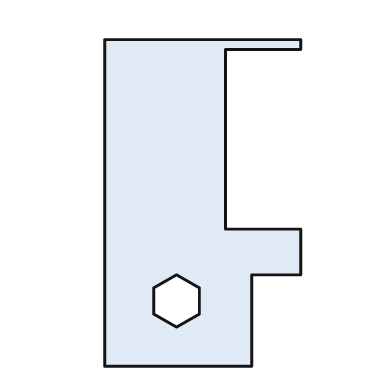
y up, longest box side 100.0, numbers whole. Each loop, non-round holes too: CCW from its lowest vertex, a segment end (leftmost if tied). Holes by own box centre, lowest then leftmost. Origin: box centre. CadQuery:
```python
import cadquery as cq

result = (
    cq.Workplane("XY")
    .moveTo(-30.0, -50.0)
    .lineTo(15.0, -50.0)
    .lineTo(15.0, -22.0)
    .lineTo(30.0, -22.0)
    .lineTo(30.0, -8.0)
    .lineTo(7.0, -8.0)
    .lineTo(7.0, 47.0)
    .lineTo(30.0, 47.0)
    .lineTo(30.0, 50.0)
    .lineTo(-30.0, 50.0)
    .close()
    .moveTo(-8.0, -38.0)
    .lineTo(-1.0, -34.0)
    .lineTo(-1.0, -26.0)
    .lineTo(-8.0, -22.0)
    .lineTo(-15.0, -26.0)
    .lineTo(-15.0, -34.0)
    .close()
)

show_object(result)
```